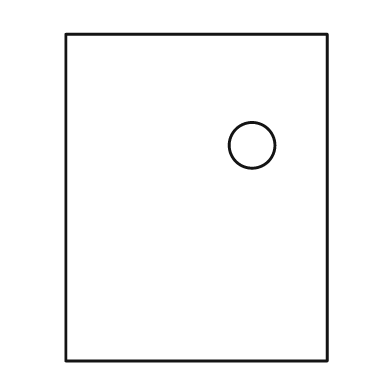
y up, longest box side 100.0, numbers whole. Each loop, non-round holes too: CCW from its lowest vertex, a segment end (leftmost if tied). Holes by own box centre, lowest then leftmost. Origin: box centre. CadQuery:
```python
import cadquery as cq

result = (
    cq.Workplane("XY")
    .moveTo(-40.0, -50.0)
    .lineTo(40.0, -50.0)
    .lineTo(40.0, 50.0)
    .lineTo(-40.0, 50.0)
    .close()
    .moveTo(17.0, 16.0)
    .circle(7.0)
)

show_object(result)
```